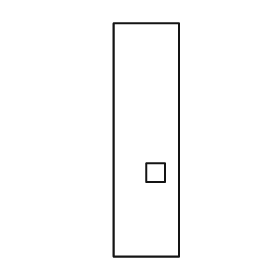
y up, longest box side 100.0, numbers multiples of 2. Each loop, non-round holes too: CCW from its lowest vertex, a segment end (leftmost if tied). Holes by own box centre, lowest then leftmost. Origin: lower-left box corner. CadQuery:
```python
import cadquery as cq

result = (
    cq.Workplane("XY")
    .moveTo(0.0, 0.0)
    .lineTo(28.0, 0.0)
    .lineTo(28.0, 100.0)
    .lineTo(0.0, 100.0)
    .close()
    .moveTo(14.0, 32.0)
    .lineTo(22.0, 32.0)
    .lineTo(22.0, 40.0)
    .lineTo(14.0, 40.0)
    .close()
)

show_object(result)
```